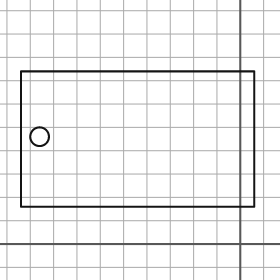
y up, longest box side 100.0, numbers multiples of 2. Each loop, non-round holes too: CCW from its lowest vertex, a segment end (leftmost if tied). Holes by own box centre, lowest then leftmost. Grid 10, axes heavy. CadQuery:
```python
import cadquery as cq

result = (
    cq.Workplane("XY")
    .moveTo(-94.0, 16.0)
    .lineTo(6.0, 16.0)
    .lineTo(6.0, 74.0)
    .lineTo(-94.0, 74.0)
    .close()
    .moveTo(-86.0, 46.0)
    .circle(4.0)
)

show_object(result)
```